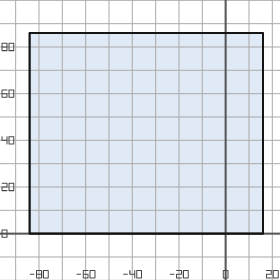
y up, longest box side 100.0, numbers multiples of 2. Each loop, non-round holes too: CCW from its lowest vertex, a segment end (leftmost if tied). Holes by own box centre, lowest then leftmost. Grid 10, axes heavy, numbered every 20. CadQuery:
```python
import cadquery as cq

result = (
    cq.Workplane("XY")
    .moveTo(-84.0, 0.0)
    .lineTo(16.0, 0.0)
    .lineTo(16.0, 86.0)
    .lineTo(-84.0, 86.0)
    .close()
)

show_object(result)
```